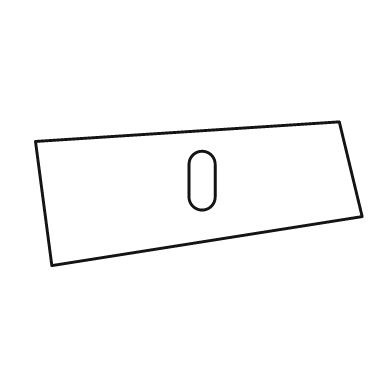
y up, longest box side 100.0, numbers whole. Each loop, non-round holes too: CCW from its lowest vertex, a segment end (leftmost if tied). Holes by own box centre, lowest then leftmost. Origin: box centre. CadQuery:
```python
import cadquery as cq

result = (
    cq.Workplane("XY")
    .moveTo(-45.0, -22.0)
    .lineTo(50.0, -7.0)
    .lineTo(43.0, 22.0)
    .lineTo(-50.0, 16.0)
    .close()
    .moveTo(-3.0, -1.0)
    .threePointArc((1.0, -5.0), (5.0, -1.0))
    .lineTo(5.0, 9.0)
    .threePointArc((1.0, 13.0), (-3.0, 9.0))
    .close()
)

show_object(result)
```